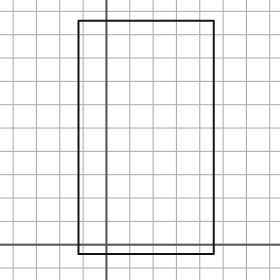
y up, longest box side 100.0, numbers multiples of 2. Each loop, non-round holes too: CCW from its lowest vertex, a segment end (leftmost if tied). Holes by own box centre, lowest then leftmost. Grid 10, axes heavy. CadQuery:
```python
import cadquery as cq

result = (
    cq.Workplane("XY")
    .moveTo(-12.0, -4.0)
    .lineTo(46.0, -4.0)
    .lineTo(46.0, 96.0)
    .lineTo(-12.0, 96.0)
    .close()
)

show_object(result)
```